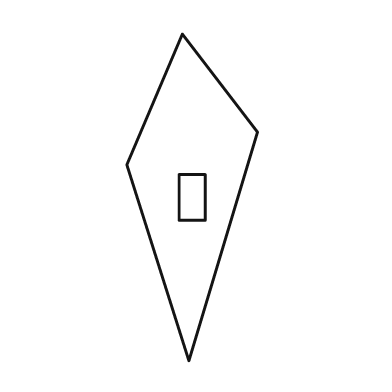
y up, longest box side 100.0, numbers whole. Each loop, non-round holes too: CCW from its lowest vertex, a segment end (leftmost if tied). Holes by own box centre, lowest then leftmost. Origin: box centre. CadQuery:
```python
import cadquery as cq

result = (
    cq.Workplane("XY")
    .moveTo(-1.0, -50.0)
    .lineTo(20.0, 20.0)
    .lineTo(-3.0, 50.0)
    .lineTo(-20.0, 10.0)
    .close()
    .moveTo(-4.0, -7.0)
    .lineTo(4.0, -7.0)
    .lineTo(4.0, 7.0)
    .lineTo(-4.0, 7.0)
    .close()
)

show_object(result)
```